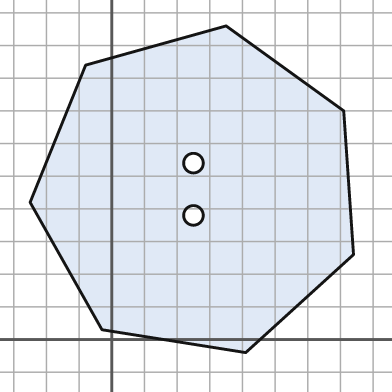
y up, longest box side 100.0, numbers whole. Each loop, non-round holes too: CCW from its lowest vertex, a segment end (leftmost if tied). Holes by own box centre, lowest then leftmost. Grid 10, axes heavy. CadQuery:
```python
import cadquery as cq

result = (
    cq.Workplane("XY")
    .moveTo(41.0, -4.0)
    .lineTo(74.0, 26.0)
    .lineTo(71.0, 70.0)
    .lineTo(35.0, 96.0)
    .lineTo(-8.0, 84.0)
    .lineTo(-25.0, 42.0)
    .lineTo(-3.0, 3.0)
    .close()
    .moveTo(25.0, 38.0)
    .circle(3.0)
    .moveTo(25.0, 54.0)
    .circle(3.0)
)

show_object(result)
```